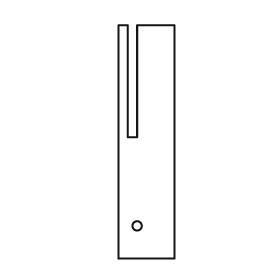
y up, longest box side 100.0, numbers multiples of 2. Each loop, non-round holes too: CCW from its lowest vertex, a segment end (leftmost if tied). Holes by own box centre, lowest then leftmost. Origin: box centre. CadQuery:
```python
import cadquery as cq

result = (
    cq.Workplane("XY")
    .moveTo(-12.0, -50.0)
    .lineTo(12.0, -50.0)
    .lineTo(12.0, 50.0)
    .lineTo(-4.0, 50.0)
    .lineTo(-4.0, 2.0)
    .lineTo(-8.0, 2.0)
    .lineTo(-8.0, 50.0)
    .lineTo(-12.0, 50.0)
    .close()
    .moveTo(-4.0, -36.0)
    .circle(2.0)
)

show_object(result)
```